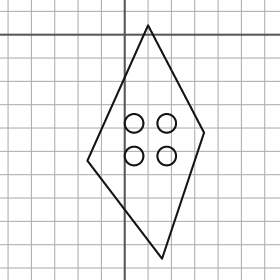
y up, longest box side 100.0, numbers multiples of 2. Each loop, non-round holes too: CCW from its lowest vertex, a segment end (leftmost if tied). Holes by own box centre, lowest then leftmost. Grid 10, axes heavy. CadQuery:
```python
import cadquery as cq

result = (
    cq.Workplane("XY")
    .moveTo(16.0, -96.0)
    .lineTo(34.0, -42.0)
    .lineTo(10.0, 4.0)
    .lineTo(-16.0, -54.0)
    .close()
    .moveTo(4.0, -52.0)
    .circle(4.0)
    .moveTo(18.0, -52.0)
    .circle(4.0)
    .moveTo(4.0, -38.0)
    .circle(4.0)
    .moveTo(18.0, -38.0)
    .circle(4.0)
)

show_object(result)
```